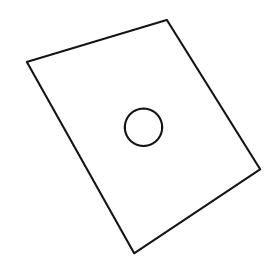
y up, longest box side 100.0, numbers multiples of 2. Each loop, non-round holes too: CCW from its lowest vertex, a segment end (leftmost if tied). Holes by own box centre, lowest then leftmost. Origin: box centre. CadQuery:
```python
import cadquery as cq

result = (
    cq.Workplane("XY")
    .moveTo(-4.0, -50.0)
    .lineTo(50.0, -14.0)
    .lineTo(10.0, 50.0)
    .lineTo(-50.0, 32.0)
    .close()
    .moveTo(0.0, 4.0)
    .circle(8.0)
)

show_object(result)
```